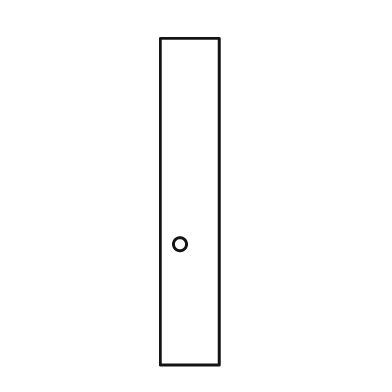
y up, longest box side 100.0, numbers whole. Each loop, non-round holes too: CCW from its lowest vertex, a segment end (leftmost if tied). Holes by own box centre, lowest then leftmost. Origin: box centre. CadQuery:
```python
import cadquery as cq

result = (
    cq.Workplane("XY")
    .moveTo(-9.0, -50.0)
    .lineTo(9.0, -50.0)
    .lineTo(9.0, 50.0)
    .lineTo(-9.0, 50.0)
    .close()
    .moveTo(-3.0, -13.0)
    .circle(2.0)
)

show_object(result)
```